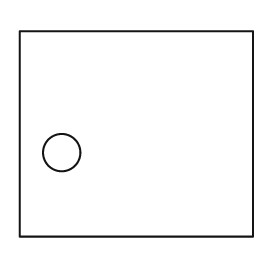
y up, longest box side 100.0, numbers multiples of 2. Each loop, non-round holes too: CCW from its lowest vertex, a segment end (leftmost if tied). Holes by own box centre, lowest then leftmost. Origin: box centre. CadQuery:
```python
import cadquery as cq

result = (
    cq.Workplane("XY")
    .moveTo(-50.0, -44.0)
    .lineTo(50.0, -44.0)
    .lineTo(50.0, 44.0)
    .lineTo(-50.0, 44.0)
    .close()
    .moveTo(-32.0, -8.0)
    .circle(8.0)
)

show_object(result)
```